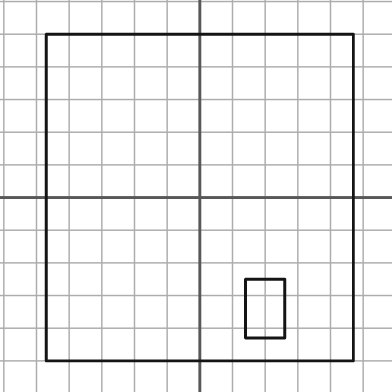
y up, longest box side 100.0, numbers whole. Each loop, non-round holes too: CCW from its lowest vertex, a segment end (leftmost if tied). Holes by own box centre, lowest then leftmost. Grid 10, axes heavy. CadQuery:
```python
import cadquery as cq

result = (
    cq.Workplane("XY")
    .moveTo(-47.0, -50.0)
    .lineTo(47.0, -50.0)
    .lineTo(47.0, 50.0)
    .lineTo(-47.0, 50.0)
    .close()
    .moveTo(14.0, -43.0)
    .lineTo(26.0, -43.0)
    .lineTo(26.0, -25.0)
    .lineTo(14.0, -25.0)
    .close()
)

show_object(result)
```